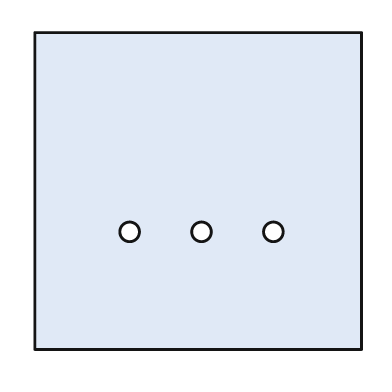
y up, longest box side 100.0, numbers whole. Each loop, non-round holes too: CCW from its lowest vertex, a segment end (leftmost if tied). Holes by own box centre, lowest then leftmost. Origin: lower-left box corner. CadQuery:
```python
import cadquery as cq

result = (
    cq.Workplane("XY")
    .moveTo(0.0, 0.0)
    .lineTo(100.0, 0.0)
    .lineTo(100.0, 97.0)
    .lineTo(0.0, 97.0)
    .close()
    .moveTo(29.0, 36.0)
    .circle(3.0)
    .moveTo(51.0, 36.0)
    .circle(3.0)
    .moveTo(73.0, 36.0)
    .circle(3.0)
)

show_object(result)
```